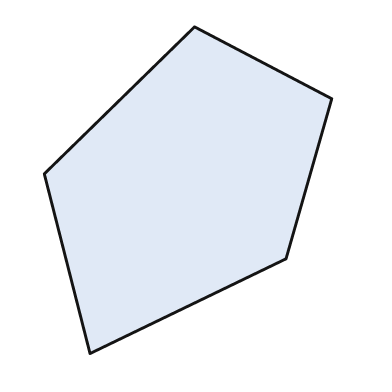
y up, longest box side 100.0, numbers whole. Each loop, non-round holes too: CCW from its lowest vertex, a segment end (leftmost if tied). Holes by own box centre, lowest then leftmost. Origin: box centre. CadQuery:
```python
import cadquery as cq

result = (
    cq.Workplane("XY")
    .moveTo(-30.0, -50.0)
    .lineTo(30.0, -21.0)
    .lineTo(44.0, 28.0)
    .lineTo(2.0, 50.0)
    .lineTo(-44.0, 5.0)
    .close()
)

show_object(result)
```